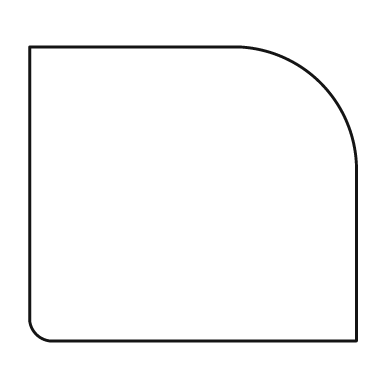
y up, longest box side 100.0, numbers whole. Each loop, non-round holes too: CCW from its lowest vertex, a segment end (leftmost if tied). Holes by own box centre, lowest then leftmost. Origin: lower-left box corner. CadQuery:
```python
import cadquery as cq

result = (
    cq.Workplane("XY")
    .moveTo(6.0, 0.0)
    .lineTo(100.0, 0.0)
    .lineTo(100.0, 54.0)
    .threePointArc((89.0, 79.0), (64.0, 90.0))
    .lineTo(0.0, 90.0)
    .lineTo(0.0, 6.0)
    .threePointArc((2.0, 2.0), (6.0, 0.0))
    .close()
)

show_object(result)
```